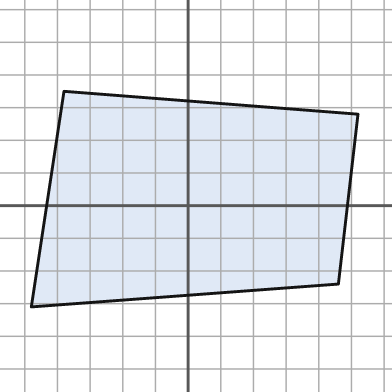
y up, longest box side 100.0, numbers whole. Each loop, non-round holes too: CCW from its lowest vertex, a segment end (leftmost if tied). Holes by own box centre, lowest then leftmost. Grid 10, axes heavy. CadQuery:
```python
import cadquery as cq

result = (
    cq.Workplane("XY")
    .moveTo(-48.0, -31.0)
    .lineTo(46.0, -24.0)
    .lineTo(52.0, 28.0)
    .lineTo(-38.0, 35.0)
    .close()
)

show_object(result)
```